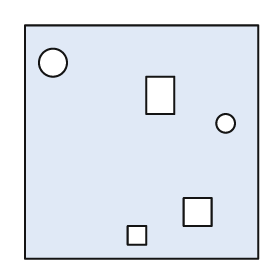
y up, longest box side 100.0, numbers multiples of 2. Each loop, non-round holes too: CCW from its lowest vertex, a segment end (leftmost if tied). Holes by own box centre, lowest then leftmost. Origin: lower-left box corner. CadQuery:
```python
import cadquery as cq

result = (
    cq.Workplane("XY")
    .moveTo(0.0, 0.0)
    .lineTo(100.0, 0.0)
    .lineTo(100.0, 100.0)
    .lineTo(0.0, 100.0)
    .close()
    .moveTo(44.0, 6.0)
    .lineTo(52.0, 6.0)
    .lineTo(52.0, 14.0)
    .lineTo(44.0, 14.0)
    .close()
    .moveTo(68.0, 14.0)
    .lineTo(80.0, 14.0)
    .lineTo(80.0, 26.0)
    .lineTo(68.0, 26.0)
    .close()
    .moveTo(86.0, 58.0)
    .circle(4.0)
    .moveTo(52.0, 62.0)
    .lineTo(64.0, 62.0)
    .lineTo(64.0, 78.0)
    .lineTo(52.0, 78.0)
    .close()
    .moveTo(12.0, 84.0)
    .circle(6.0)
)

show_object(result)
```